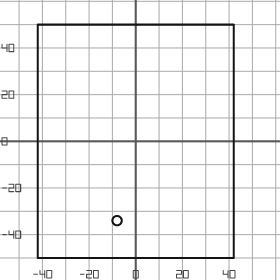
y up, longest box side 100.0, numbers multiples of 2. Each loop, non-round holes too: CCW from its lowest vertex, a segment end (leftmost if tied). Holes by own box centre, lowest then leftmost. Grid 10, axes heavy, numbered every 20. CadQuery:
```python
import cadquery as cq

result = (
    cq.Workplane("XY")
    .moveTo(-42.0, -50.0)
    .lineTo(42.0, -50.0)
    .lineTo(42.0, 50.0)
    .lineTo(-42.0, 50.0)
    .close()
    .moveTo(-8.0, -34.0)
    .circle(2.0)
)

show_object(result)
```